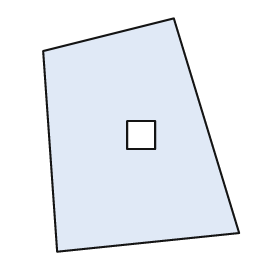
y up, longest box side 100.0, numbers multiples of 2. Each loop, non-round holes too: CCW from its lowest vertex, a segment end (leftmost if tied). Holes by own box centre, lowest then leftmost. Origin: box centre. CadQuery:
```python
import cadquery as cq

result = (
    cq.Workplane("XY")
    .moveTo(-36.0, -50.0)
    .lineTo(42.0, -42.0)
    .lineTo(14.0, 50.0)
    .lineTo(-42.0, 36.0)
    .close()
    .moveTo(-6.0, -6.0)
    .lineTo(6.0, -6.0)
    .lineTo(6.0, 6.0)
    .lineTo(-6.0, 6.0)
    .close()
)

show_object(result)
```